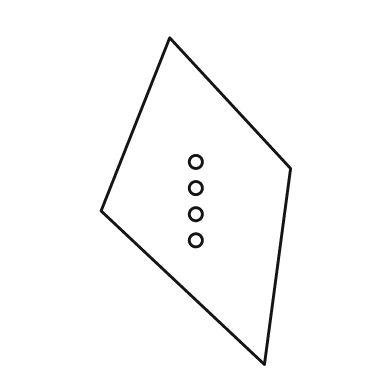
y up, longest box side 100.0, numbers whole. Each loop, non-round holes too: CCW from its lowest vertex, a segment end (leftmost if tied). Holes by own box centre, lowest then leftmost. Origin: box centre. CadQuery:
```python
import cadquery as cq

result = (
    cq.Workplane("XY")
    .moveTo(21.0, -50.0)
    .lineTo(29.0, 10.0)
    .lineTo(-8.0, 50.0)
    .lineTo(-29.0, -3.0)
    .close()
    .moveTo(0.0, -12.0)
    .circle(2.0)
    .moveTo(0.0, -4.0)
    .circle(2.0)
    .moveTo(0.0, 4.0)
    .circle(2.0)
    .moveTo(0.0, 12.0)
    .circle(2.0)
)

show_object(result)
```